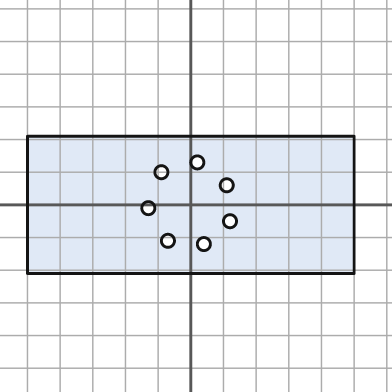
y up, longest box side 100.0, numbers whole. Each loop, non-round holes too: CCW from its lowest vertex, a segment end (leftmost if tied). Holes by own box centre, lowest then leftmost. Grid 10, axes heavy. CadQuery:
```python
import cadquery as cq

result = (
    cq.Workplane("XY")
    .moveTo(-50.0, -21.0)
    .lineTo(50.0, -21.0)
    .lineTo(50.0, 21.0)
    .lineTo(-50.0, 21.0)
    .close()
    .moveTo(4.0, -12.0)
    .circle(2.0)
    .moveTo(-7.0, -11.0)
    .circle(2.0)
    .moveTo(12.0, -5.0)
    .circle(2.0)
    .moveTo(-13.0, -1.0)
    .circle(2.0)
    .moveTo(11.0, 6.0)
    .circle(2.0)
    .moveTo(-9.0, 10.0)
    .circle(2.0)
    .moveTo(2.0, 13.0)
    .circle(2.0)
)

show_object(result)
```